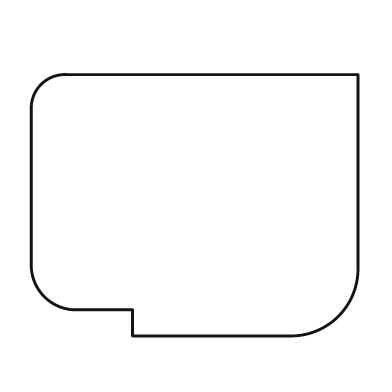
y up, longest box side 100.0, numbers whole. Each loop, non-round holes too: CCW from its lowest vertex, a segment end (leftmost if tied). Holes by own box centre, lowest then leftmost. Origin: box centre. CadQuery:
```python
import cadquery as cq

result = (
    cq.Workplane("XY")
    .moveTo(-19.0, -40.0)
    .lineTo(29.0, -40.0)
    .threePointArc((44.0, -34.0), (50.0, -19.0))
    .lineTo(50.0, 40.0)
    .lineTo(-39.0, 40.0)
    .threePointArc((-47.0, 37.0), (-50.0, 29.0))
    .lineTo(-50.0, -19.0)
    .threePointArc((-46.0, -28.0), (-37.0, -32.0))
    .lineTo(-19.0, -32.0)
    .close()
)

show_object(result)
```